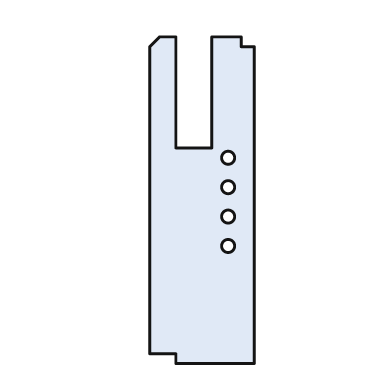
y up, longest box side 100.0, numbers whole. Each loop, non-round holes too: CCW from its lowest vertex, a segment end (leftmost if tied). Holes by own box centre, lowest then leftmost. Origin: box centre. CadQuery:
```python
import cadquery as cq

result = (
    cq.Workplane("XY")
    .moveTo(-8.0, -50.0)
    .lineTo(16.0, -50.0)
    .lineTo(16.0, 47.0)
    .lineTo(12.0, 47.0)
    .lineTo(12.0, 50.0)
    .lineTo(3.0, 50.0)
    .lineTo(3.0, 16.0)
    .lineTo(-8.0, 16.0)
    .lineTo(-8.0, 50.0)
    .lineTo(-13.0, 50.0)
    .lineTo(-16.0, 47.0)
    .lineTo(-16.0, -47.0)
    .lineTo(-8.0, -47.0)
    .close()
    .moveTo(8.0, -14.0)
    .circle(2.0)
    .moveTo(8.0, -5.0)
    .circle(2.0)
    .moveTo(8.0, 4.0)
    .circle(2.0)
    .moveTo(8.0, 13.0)
    .circle(2.0)
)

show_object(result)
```